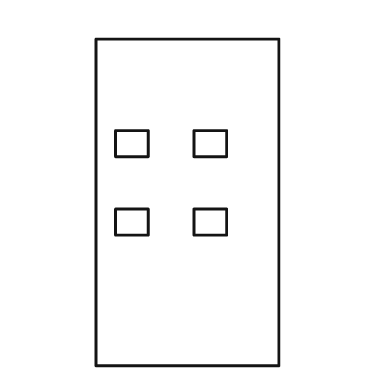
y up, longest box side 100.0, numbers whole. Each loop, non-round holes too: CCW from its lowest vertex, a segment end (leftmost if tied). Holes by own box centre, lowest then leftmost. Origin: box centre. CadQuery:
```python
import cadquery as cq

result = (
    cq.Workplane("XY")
    .moveTo(-28.0, -50.0)
    .lineTo(28.0, -50.0)
    .lineTo(28.0, 50.0)
    .lineTo(-28.0, 50.0)
    .close()
    .moveTo(-22.0, -10.0)
    .lineTo(-12.0, -10.0)
    .lineTo(-12.0, -2.0)
    .lineTo(-22.0, -2.0)
    .close()
    .moveTo(2.0, -10.0)
    .lineTo(12.0, -10.0)
    .lineTo(12.0, -2.0)
    .lineTo(2.0, -2.0)
    .close()
    .moveTo(-22.0, 14.0)
    .lineTo(-12.0, 14.0)
    .lineTo(-12.0, 22.0)
    .lineTo(-22.0, 22.0)
    .close()
    .moveTo(2.0, 14.0)
    .lineTo(12.0, 14.0)
    .lineTo(12.0, 22.0)
    .lineTo(2.0, 22.0)
    .close()
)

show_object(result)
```